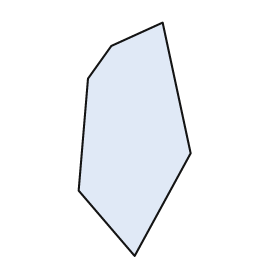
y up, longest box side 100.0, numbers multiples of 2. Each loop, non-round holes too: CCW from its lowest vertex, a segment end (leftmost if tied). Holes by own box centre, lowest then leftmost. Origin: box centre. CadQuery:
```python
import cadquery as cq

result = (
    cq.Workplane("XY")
    .moveTo(0.0, -50.0)
    .lineTo(24.0, -6.0)
    .lineTo(12.0, 50.0)
    .lineTo(-10.0, 40.0)
    .lineTo(-20.0, 26.0)
    .lineTo(-24.0, -22.0)
    .close()
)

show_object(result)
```